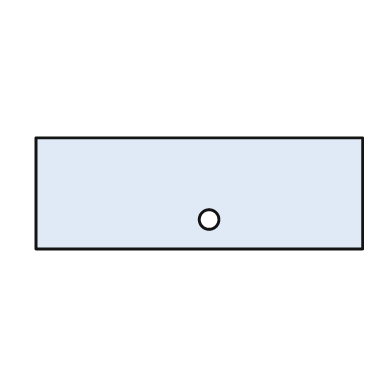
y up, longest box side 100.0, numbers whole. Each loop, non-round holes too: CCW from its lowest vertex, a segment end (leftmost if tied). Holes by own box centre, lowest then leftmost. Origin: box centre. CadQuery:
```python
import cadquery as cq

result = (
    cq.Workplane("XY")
    .moveTo(-50.0, -17.0)
    .lineTo(50.0, -17.0)
    .lineTo(50.0, 17.0)
    .lineTo(-50.0, 17.0)
    .close()
    .moveTo(3.0, -8.0)
    .circle(3.0)
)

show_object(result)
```